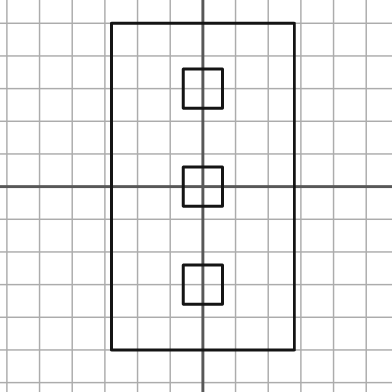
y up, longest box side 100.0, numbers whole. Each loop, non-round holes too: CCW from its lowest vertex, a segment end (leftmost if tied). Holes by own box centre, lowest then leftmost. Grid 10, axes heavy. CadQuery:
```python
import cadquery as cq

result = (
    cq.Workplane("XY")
    .moveTo(-28.0, -50.0)
    .lineTo(28.0, -50.0)
    .lineTo(28.0, 50.0)
    .lineTo(-28.0, 50.0)
    .close()
    .moveTo(-6.0, -36.0)
    .lineTo(6.0, -36.0)
    .lineTo(6.0, -24.0)
    .lineTo(-6.0, -24.0)
    .close()
    .moveTo(-6.0, -6.0)
    .lineTo(6.0, -6.0)
    .lineTo(6.0, 6.0)
    .lineTo(-6.0, 6.0)
    .close()
    .moveTo(-6.0, 24.0)
    .lineTo(6.0, 24.0)
    .lineTo(6.0, 36.0)
    .lineTo(-6.0, 36.0)
    .close()
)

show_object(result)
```